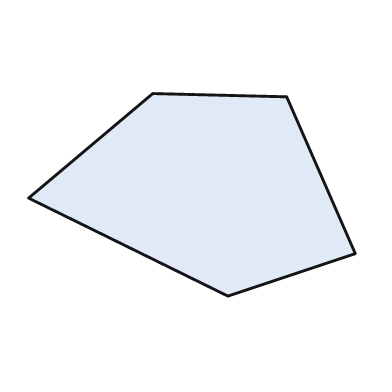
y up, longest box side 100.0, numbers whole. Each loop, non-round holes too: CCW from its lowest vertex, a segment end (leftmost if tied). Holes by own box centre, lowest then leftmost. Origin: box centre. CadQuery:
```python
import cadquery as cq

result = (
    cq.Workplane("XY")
    .moveTo(11.0, -31.0)
    .lineTo(50.0, -18.0)
    .lineTo(29.0, 30.0)
    .lineTo(-12.0, 31.0)
    .lineTo(-50.0, -1.0)
    .close()
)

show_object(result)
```